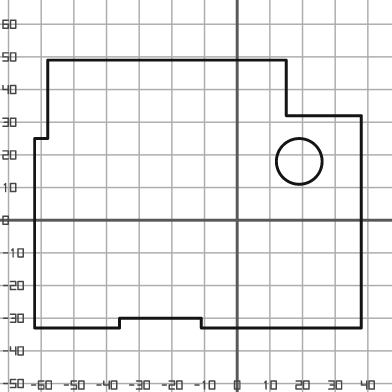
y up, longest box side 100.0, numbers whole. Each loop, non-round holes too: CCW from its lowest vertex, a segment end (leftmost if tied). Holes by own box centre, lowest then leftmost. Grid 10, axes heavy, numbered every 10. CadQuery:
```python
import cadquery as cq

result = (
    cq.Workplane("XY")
    .moveTo(-62.0, -33.0)
    .lineTo(-36.0, -33.0)
    .lineTo(-36.0, -30.0)
    .lineTo(-11.0, -30.0)
    .lineTo(-11.0, -33.0)
    .lineTo(38.0, -33.0)
    .lineTo(38.0, 32.0)
    .lineTo(15.0, 32.0)
    .lineTo(15.0, 49.0)
    .lineTo(-58.0, 49.0)
    .lineTo(-58.0, 25.0)
    .lineTo(-62.0, 25.0)
    .close()
    .moveTo(19.0, 18.0)
    .circle(7.0)
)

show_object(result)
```